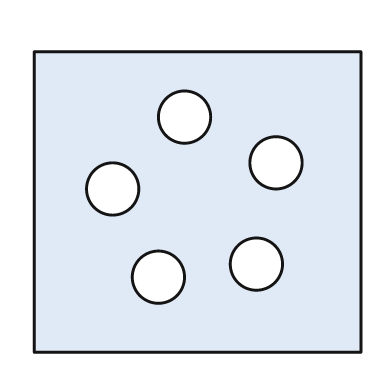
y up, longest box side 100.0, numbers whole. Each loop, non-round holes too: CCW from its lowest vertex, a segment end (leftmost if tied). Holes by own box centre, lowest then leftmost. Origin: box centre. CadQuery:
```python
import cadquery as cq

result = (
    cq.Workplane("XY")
    .moveTo(-50.0, -46.0)
    .lineTo(50.0, -46.0)
    .lineTo(50.0, 46.0)
    .lineTo(-50.0, 46.0)
    .close()
    .moveTo(-12.0, -23.0)
    .circle(8.0)
    .moveTo(18.0, -19.0)
    .circle(8.0)
    .moveTo(-26.0, 4.0)
    .circle(8.0)
    .moveTo(24.0, 12.0)
    .circle(8.0)
    .moveTo(-4.0, 26.0)
    .circle(8.0)
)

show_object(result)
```